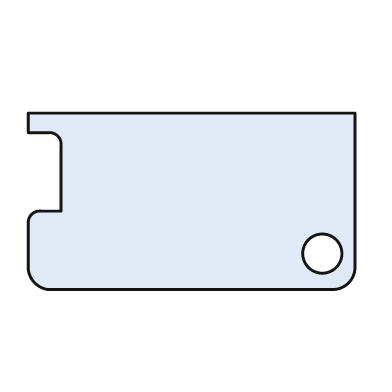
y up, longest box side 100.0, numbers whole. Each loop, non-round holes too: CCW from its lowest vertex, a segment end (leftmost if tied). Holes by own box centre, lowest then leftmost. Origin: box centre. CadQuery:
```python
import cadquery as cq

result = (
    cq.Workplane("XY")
    .moveTo(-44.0, -27.0)
    .lineTo(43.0, -27.0)
    .threePointArc((48.0, -25.0), (50.0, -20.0))
    .lineTo(50.0, 27.0)
    .lineTo(-50.0, 27.0)
    .lineTo(-50.0, 21.0)
    .lineTo(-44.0, 21.0)
    .threePointArc((-41.0, 20.0), (-40.0, 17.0))
    .lineTo(-40.0, -3.0)
    .lineTo(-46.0, -3.0)
    .threePointArc((-49.0, -4.0), (-50.0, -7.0))
    .lineTo(-50.0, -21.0)
    .threePointArc((-48.0, -25.0), (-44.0, -27.0))
    .close()
    .moveTo(40.0, -16.0)
    .circle(6.0)
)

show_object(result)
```